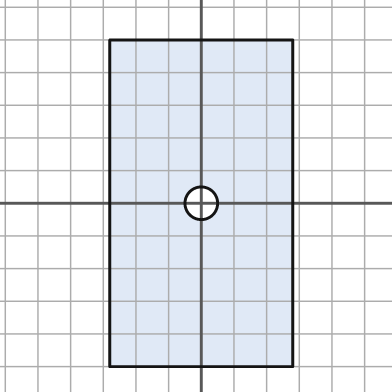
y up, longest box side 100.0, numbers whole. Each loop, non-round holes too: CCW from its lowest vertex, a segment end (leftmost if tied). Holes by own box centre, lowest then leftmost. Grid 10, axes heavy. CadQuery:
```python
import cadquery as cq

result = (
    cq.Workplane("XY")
    .moveTo(-28.0, -50.0)
    .lineTo(28.0, -50.0)
    .lineTo(28.0, 50.0)
    .lineTo(-28.0, 50.0)
    .close()
    .moveTo(0.0, 0.0)
    .circle(5.0)
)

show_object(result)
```